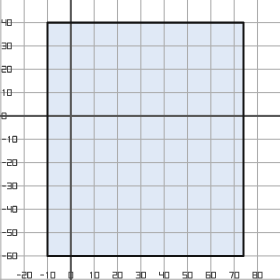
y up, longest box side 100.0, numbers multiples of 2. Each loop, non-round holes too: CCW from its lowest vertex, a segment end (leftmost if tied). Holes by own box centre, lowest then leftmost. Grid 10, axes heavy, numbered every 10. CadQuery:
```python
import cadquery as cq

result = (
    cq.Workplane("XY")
    .moveTo(-10.0, -60.0)
    .lineTo(74.0, -60.0)
    .lineTo(74.0, 40.0)
    .lineTo(-10.0, 40.0)
    .close()
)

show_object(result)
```